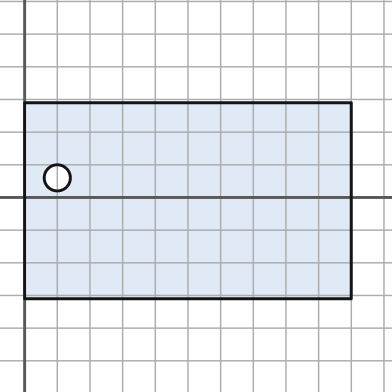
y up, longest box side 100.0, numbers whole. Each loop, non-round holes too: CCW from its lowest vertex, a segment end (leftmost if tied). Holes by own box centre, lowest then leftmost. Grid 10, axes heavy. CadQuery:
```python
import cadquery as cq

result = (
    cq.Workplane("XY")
    .moveTo(0.0, -31.0)
    .lineTo(100.0, -31.0)
    .lineTo(100.0, 29.0)
    .lineTo(0.0, 29.0)
    .close()
    .moveTo(10.0, 6.0)
    .circle(4.0)
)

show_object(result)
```